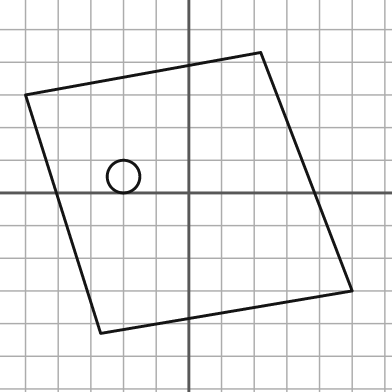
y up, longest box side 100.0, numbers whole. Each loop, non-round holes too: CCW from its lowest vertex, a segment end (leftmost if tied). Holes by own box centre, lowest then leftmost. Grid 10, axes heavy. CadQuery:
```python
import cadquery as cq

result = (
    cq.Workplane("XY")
    .moveTo(-27.0, -43.0)
    .lineTo(50.0, -30.0)
    .lineTo(22.0, 43.0)
    .lineTo(-50.0, 30.0)
    .close()
    .moveTo(-20.0, 5.0)
    .circle(5.0)
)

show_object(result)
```